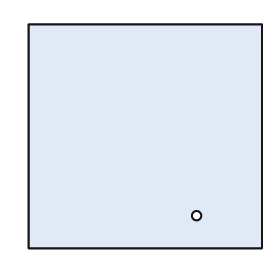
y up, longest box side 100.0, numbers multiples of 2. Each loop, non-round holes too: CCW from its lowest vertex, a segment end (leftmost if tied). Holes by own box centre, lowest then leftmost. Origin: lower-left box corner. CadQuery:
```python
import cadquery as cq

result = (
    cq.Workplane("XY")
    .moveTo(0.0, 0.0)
    .lineTo(100.0, 0.0)
    .lineTo(100.0, 96.0)
    .lineTo(0.0, 96.0)
    .close()
    .moveTo(72.0, 14.0)
    .circle(2.0)
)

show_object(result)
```